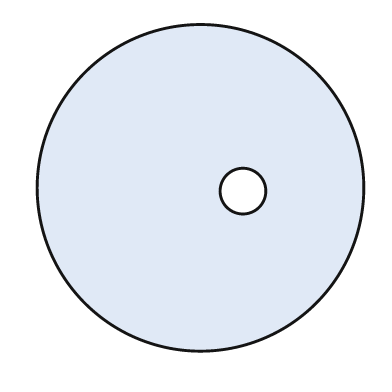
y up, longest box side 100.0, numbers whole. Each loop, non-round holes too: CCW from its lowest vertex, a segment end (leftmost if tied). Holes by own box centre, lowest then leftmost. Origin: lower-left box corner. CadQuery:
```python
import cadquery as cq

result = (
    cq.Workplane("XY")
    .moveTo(50.0, 50.0)
    .circle(50.0)
    .moveTo(63.0, 49.0)
    .circle(7.0)
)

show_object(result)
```